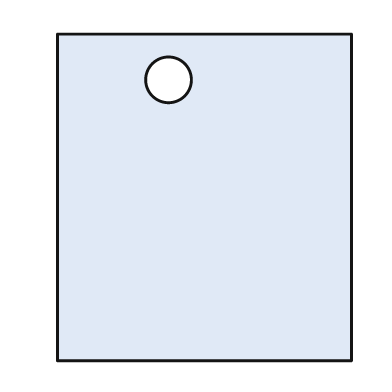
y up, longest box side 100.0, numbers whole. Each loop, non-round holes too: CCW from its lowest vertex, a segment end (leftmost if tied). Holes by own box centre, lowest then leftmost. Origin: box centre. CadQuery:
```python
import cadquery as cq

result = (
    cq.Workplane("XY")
    .moveTo(-45.0, -50.0)
    .lineTo(45.0, -50.0)
    .lineTo(45.0, 50.0)
    .lineTo(-45.0, 50.0)
    .close()
    .moveTo(-11.0, 36.0)
    .circle(7.0)
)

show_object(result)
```